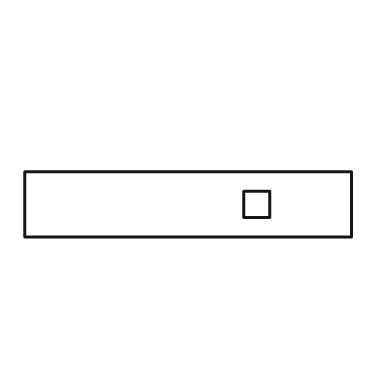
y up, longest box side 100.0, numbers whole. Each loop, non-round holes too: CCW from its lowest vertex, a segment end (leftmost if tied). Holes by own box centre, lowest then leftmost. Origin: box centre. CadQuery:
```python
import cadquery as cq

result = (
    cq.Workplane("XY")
    .moveTo(-50.0, -10.0)
    .lineTo(50.0, -10.0)
    .lineTo(50.0, 10.0)
    .lineTo(-50.0, 10.0)
    .close()
    .moveTo(17.0, -4.0)
    .lineTo(25.0, -4.0)
    .lineTo(25.0, 4.0)
    .lineTo(17.0, 4.0)
    .close()
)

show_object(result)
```